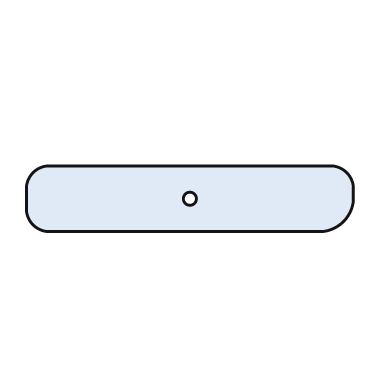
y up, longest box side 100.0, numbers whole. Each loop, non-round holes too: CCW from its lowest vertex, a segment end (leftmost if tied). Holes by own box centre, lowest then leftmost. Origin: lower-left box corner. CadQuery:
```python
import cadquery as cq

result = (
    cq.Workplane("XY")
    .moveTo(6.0, 0.0)
    .lineTo(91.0, 0.0)
    .threePointArc((97.0, 3.0), (100.0, 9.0))
    .lineTo(100.0, 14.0)
    .threePointArc((98.0, 18.0), (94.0, 20.0))
    .lineTo(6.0, 20.0)
    .threePointArc((2.0, 18.0), (0.0, 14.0))
    .lineTo(0.0, 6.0)
    .threePointArc((2.0, 2.0), (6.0, 0.0))
    .close()
    .moveTo(50.0, 10.0)
    .circle(2.0)
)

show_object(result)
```